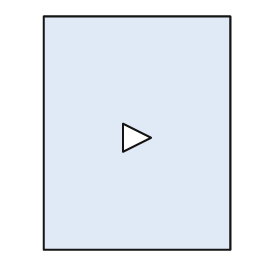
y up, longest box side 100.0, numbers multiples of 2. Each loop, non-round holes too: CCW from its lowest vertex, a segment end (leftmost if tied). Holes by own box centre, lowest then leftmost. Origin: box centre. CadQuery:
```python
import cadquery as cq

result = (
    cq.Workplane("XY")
    .moveTo(-40.0, -50.0)
    .lineTo(40.0, -50.0)
    .lineTo(40.0, 50.0)
    .lineTo(-40.0, 50.0)
    .close()
    .moveTo(-6.0, -8.0)
    .lineTo(6.0, -2.0)
    .lineTo(-6.0, 4.0)
    .close()
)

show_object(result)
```